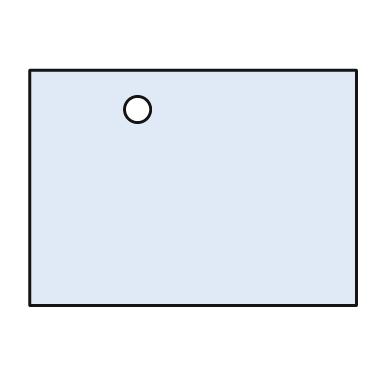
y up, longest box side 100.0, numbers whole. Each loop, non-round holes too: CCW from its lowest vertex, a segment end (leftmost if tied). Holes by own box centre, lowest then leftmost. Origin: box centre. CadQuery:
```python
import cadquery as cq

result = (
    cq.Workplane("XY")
    .moveTo(-50.0, -36.0)
    .lineTo(50.0, -36.0)
    .lineTo(50.0, 36.0)
    .lineTo(-50.0, 36.0)
    .close()
    .moveTo(-17.0, 24.0)
    .circle(4.0)
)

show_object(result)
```